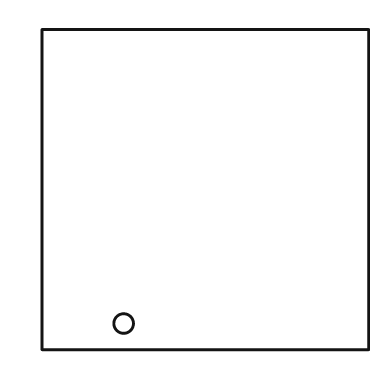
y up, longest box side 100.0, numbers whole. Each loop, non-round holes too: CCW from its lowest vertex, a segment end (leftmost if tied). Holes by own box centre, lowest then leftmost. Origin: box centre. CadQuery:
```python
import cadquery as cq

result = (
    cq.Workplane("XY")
    .moveTo(-50.0, -49.0)
    .lineTo(50.0, -49.0)
    .lineTo(50.0, 49.0)
    .lineTo(-50.0, 49.0)
    .close()
    .moveTo(-25.0, -41.0)
    .circle(3.0)
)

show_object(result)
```